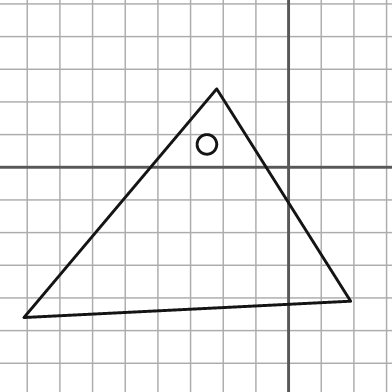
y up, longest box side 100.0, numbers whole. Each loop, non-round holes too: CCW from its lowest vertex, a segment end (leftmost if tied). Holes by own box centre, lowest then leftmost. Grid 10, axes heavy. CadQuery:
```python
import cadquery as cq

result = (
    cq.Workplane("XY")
    .moveTo(-81.0, -46.0)
    .lineTo(19.0, -41.0)
    .lineTo(-22.0, 24.0)
    .close()
    .moveTo(-25.0, 7.0)
    .circle(3.0)
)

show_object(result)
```